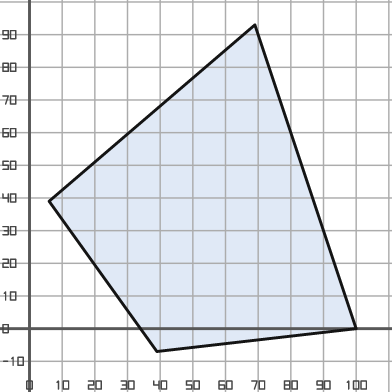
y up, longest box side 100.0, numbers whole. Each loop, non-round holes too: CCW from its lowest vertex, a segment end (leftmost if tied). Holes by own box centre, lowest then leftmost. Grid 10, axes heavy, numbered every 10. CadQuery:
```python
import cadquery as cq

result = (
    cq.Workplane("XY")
    .moveTo(39.0, -7.0)
    .lineTo(100.0, 0.0)
    .lineTo(69.0, 93.0)
    .lineTo(6.0, 39.0)
    .close()
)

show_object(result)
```